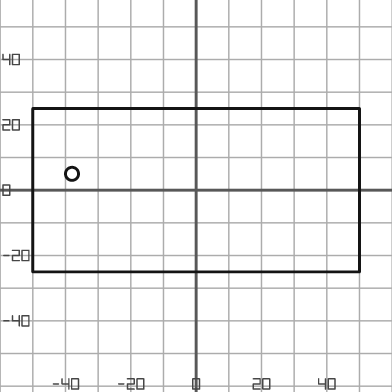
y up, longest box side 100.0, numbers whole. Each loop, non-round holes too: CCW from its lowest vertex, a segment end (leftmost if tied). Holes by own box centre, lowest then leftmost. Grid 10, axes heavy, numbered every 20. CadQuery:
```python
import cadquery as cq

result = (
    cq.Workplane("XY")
    .moveTo(-50.0, -25.0)
    .lineTo(50.0, -25.0)
    .lineTo(50.0, 25.0)
    .lineTo(-50.0, 25.0)
    .close()
    .moveTo(-38.0, 5.0)
    .circle(2.0)
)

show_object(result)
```